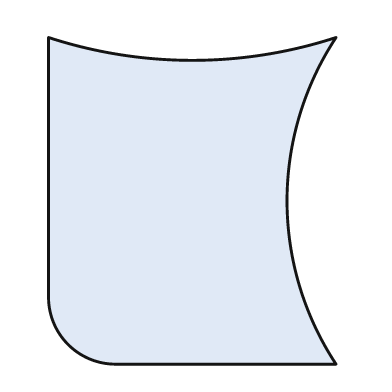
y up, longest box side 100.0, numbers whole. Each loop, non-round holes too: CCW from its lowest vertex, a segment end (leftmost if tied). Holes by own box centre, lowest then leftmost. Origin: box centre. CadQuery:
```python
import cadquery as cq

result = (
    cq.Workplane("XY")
    .moveTo(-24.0, -50.0)
    .lineTo(44.0, -50.0)
    .threePointArc((29.0, 0.0), (44.0, 50.0))
    .threePointArc((0.0, 43.0), (-44.0, 50.0))
    .lineTo(-44.0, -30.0)
    .threePointArc((-38.0, -44.0), (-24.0, -50.0))
    .close()
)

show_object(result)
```